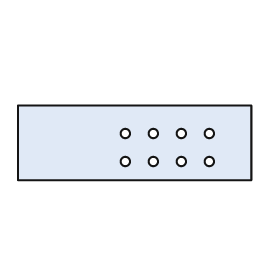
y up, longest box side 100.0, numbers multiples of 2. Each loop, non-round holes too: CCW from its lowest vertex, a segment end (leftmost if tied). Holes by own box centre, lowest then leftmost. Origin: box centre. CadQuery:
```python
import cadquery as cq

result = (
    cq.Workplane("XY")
    .moveTo(-50.0, -16.0)
    .lineTo(50.0, -16.0)
    .lineTo(50.0, 16.0)
    .lineTo(-50.0, 16.0)
    .close()
    .moveTo(-4.0, -8.0)
    .circle(2.0)
    .moveTo(8.0, -8.0)
    .circle(2.0)
    .moveTo(20.0, -8.0)
    .circle(2.0)
    .moveTo(32.0, -8.0)
    .circle(2.0)
    .moveTo(-4.0, 4.0)
    .circle(2.0)
    .moveTo(8.0, 4.0)
    .circle(2.0)
    .moveTo(20.0, 4.0)
    .circle(2.0)
    .moveTo(32.0, 4.0)
    .circle(2.0)
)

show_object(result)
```